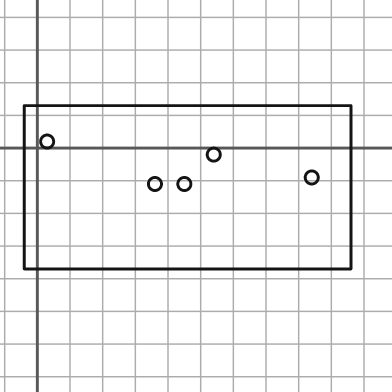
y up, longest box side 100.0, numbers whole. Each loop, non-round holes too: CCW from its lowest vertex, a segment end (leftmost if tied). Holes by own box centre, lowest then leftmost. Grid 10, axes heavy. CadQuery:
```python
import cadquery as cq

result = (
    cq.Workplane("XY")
    .moveTo(-4.0, -37.0)
    .lineTo(96.0, -37.0)
    .lineTo(96.0, 13.0)
    .lineTo(-4.0, 13.0)
    .close()
    .moveTo(36.0, -11.0)
    .circle(2.0)
    .moveTo(45.0, -11.0)
    .circle(2.0)
    .moveTo(84.0, -9.0)
    .circle(2.0)
    .moveTo(54.0, -2.0)
    .circle(2.0)
    .moveTo(3.0, 2.0)
    .circle(2.0)
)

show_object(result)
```